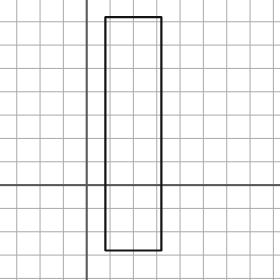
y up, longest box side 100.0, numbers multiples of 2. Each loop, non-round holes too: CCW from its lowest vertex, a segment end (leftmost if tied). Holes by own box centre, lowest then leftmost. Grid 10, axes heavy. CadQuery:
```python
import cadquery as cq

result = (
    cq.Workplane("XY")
    .moveTo(8.0, -28.0)
    .lineTo(32.0, -28.0)
    .lineTo(32.0, 72.0)
    .lineTo(8.0, 72.0)
    .close()
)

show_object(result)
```